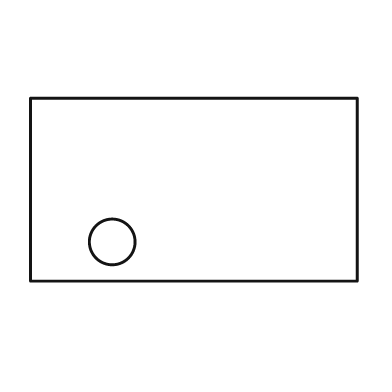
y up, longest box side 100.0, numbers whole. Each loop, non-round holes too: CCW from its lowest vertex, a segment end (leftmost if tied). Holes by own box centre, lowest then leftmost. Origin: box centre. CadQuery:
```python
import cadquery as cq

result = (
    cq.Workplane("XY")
    .moveTo(-50.0, -28.0)
    .lineTo(50.0, -28.0)
    .lineTo(50.0, 28.0)
    .lineTo(-50.0, 28.0)
    .close()
    .moveTo(-25.0, -16.0)
    .circle(7.0)
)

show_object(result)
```